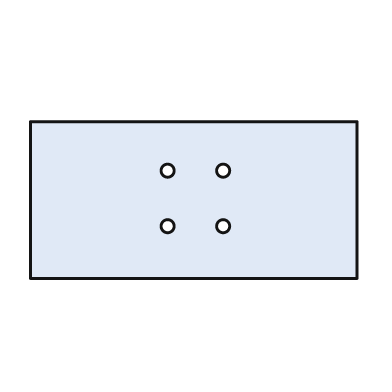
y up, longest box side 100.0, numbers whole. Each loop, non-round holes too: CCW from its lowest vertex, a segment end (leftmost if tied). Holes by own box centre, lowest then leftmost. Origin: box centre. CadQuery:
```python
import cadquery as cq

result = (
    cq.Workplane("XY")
    .moveTo(-50.0, -24.0)
    .lineTo(50.0, -24.0)
    .lineTo(50.0, 24.0)
    .lineTo(-50.0, 24.0)
    .close()
    .moveTo(-8.0, -8.0)
    .circle(2.0)
    .moveTo(9.0, -8.0)
    .circle(2.0)
    .moveTo(-8.0, 9.0)
    .circle(2.0)
    .moveTo(9.0, 9.0)
    .circle(2.0)
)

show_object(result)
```